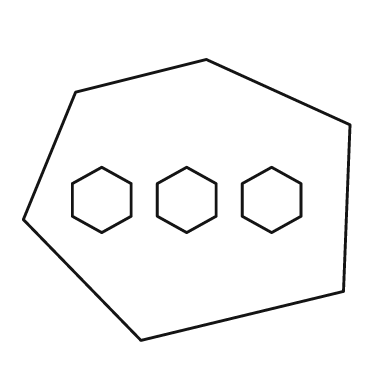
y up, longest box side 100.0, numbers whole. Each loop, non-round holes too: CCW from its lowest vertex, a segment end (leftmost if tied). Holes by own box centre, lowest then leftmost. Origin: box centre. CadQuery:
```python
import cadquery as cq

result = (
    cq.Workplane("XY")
    .moveTo(-14.0, -43.0)
    .lineTo(48.0, -28.0)
    .lineTo(50.0, 23.0)
    .lineTo(6.0, 43.0)
    .lineTo(-34.0, 33.0)
    .lineTo(-50.0, -6.0)
    .close()
    .moveTo(-26.0, -10.0)
    .lineTo(-17.0, -5.0)
    .lineTo(-17.0, 5.0)
    .lineTo(-26.0, 10.0)
    .lineTo(-35.0, 5.0)
    .lineTo(-35.0, -5.0)
    .close()
    .moveTo(0.0, -10.0)
    .lineTo(9.0, -5.0)
    .lineTo(9.0, 5.0)
    .lineTo(0.0, 10.0)
    .lineTo(-9.0, 5.0)
    .lineTo(-9.0, -5.0)
    .close()
    .moveTo(26.0, -10.0)
    .lineTo(35.0, -5.0)
    .lineTo(35.0, 5.0)
    .lineTo(26.0, 10.0)
    .lineTo(17.0, 5.0)
    .lineTo(17.0, -5.0)
    .close()
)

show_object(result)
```